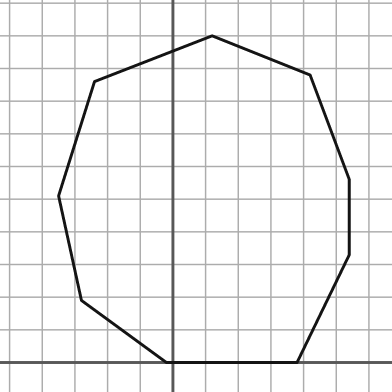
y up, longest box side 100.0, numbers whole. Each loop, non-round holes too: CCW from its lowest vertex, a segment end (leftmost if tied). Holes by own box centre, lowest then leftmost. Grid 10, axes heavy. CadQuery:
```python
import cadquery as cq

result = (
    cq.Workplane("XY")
    .moveTo(-2.0, 0.0)
    .lineTo(38.0, 0.0)
    .lineTo(54.0, 33.0)
    .lineTo(54.0, 56.0)
    .lineTo(42.0, 88.0)
    .lineTo(12.0, 100.0)
    .lineTo(-24.0, 86.0)
    .lineTo(-35.0, 51.0)
    .lineTo(-28.0, 19.0)
    .close()
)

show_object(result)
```